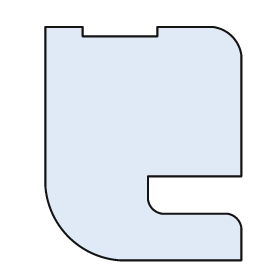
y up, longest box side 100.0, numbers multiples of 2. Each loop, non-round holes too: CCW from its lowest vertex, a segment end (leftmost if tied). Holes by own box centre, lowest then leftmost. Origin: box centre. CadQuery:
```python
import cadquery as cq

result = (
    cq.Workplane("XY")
    .moveTo(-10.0, -50.0)
    .lineTo(42.0, -50.0)
    .lineTo(42.0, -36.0)
    .threePointArc((40.0, -32.0), (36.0, -30.0))
    .lineTo(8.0, -30.0)
    .threePointArc((4.0, -28.0), (2.0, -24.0))
    .lineTo(2.0, -14.0)
    .lineTo(42.0, -14.0)
    .lineTo(42.0, 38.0)
    .threePointArc((38.0, 46.0), (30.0, 50.0))
    .lineTo(6.0, 50.0)
    .lineTo(6.0, 46.0)
    .lineTo(-26.0, 46.0)
    .lineTo(-26.0, 50.0)
    .lineTo(-42.0, 50.0)
    .lineTo(-42.0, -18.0)
    .threePointArc((-32.0, -40.0), (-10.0, -50.0))
    .close()
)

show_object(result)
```